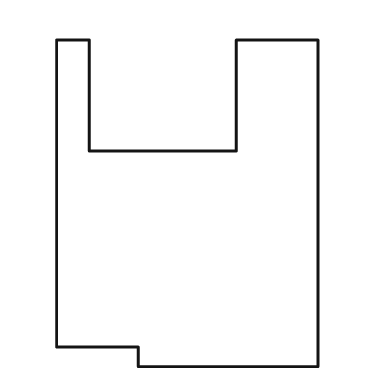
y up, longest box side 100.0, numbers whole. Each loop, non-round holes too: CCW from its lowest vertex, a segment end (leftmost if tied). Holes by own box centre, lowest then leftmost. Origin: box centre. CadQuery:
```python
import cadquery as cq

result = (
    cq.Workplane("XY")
    .moveTo(-15.0, -50.0)
    .lineTo(40.0, -50.0)
    .lineTo(40.0, 50.0)
    .lineTo(15.0, 50.0)
    .lineTo(15.0, 16.0)
    .lineTo(-30.0, 16.0)
    .lineTo(-30.0, 50.0)
    .lineTo(-40.0, 50.0)
    .lineTo(-40.0, -44.0)
    .lineTo(-15.0, -44.0)
    .close()
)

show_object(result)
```